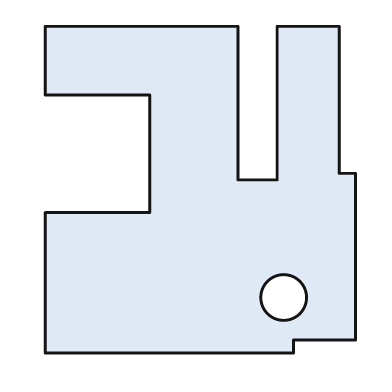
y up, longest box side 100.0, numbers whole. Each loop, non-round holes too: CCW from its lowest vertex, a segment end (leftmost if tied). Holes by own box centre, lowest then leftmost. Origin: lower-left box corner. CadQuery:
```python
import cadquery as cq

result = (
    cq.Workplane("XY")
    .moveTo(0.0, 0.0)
    .lineTo(76.0, 0.0)
    .lineTo(76.0, 4.0)
    .lineTo(95.0, 4.0)
    .lineTo(95.0, 55.0)
    .lineTo(90.0, 55.0)
    .lineTo(90.0, 100.0)
    .lineTo(71.0, 100.0)
    .lineTo(71.0, 53.0)
    .lineTo(59.0, 53.0)
    .lineTo(59.0, 100.0)
    .lineTo(0.0, 100.0)
    .lineTo(0.0, 79.0)
    .lineTo(32.0, 79.0)
    .lineTo(32.0, 43.0)
    .lineTo(0.0, 43.0)
    .close()
    .moveTo(73.0, 17.0)
    .circle(7.0)
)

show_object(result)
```